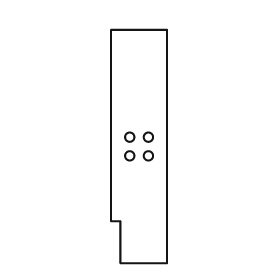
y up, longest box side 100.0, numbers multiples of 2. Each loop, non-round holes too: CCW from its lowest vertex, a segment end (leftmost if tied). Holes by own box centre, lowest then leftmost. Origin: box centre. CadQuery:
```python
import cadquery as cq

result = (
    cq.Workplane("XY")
    .moveTo(-8.0, -50.0)
    .lineTo(12.0, -50.0)
    .lineTo(12.0, 50.0)
    .lineTo(-12.0, 50.0)
    .lineTo(-12.0, -32.0)
    .lineTo(-8.0, -32.0)
    .close()
    .moveTo(-4.0, -4.0)
    .circle(2.0)
    .moveTo(4.0, -4.0)
    .circle(2.0)
    .moveTo(-4.0, 4.0)
    .circle(2.0)
    .moveTo(4.0, 4.0)
    .circle(2.0)
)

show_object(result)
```